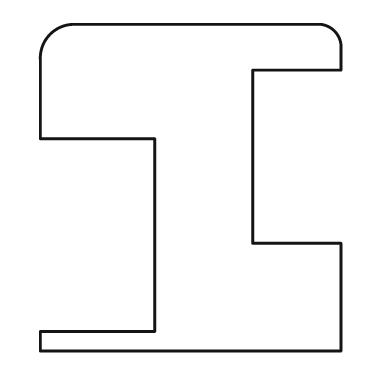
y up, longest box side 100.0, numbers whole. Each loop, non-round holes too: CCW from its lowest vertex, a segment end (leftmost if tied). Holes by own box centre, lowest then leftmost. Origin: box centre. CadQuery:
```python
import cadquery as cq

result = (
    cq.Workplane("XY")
    .moveTo(-46.0, -50.0)
    .lineTo(46.0, -50.0)
    .lineTo(46.0, -17.0)
    .lineTo(19.0, -17.0)
    .lineTo(19.0, 36.0)
    .lineTo(46.0, 36.0)
    .lineTo(46.0, 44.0)
    .threePointArc((44.0, 48.0), (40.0, 50.0))
    .lineTo(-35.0, 50.0)
    .threePointArc((-43.0, 47.0), (-46.0, 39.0))
    .lineTo(-46.0, 15.0)
    .lineTo(-11.0, 15.0)
    .lineTo(-11.0, -44.0)
    .lineTo(-46.0, -44.0)
    .close()
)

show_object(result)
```